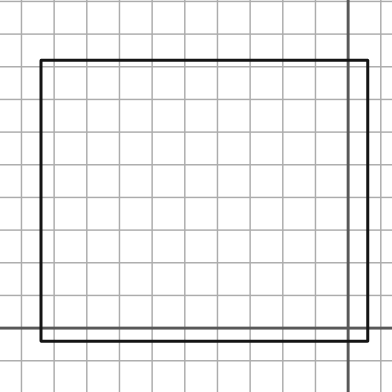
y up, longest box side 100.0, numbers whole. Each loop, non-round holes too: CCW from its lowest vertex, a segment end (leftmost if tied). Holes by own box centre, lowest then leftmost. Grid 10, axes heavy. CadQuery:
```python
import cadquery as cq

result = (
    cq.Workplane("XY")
    .moveTo(-94.0, -4.0)
    .lineTo(6.0, -4.0)
    .lineTo(6.0, 82.0)
    .lineTo(-94.0, 82.0)
    .close()
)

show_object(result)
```